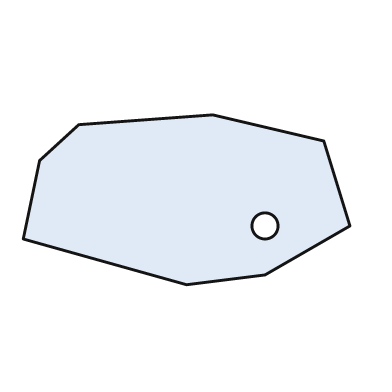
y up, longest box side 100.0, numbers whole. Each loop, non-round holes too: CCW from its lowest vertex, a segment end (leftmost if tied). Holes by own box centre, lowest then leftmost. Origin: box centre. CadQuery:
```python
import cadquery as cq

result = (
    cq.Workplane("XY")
    .moveTo(0.0, -26.0)
    .lineTo(24.0, -23.0)
    .lineTo(50.0, -8.0)
    .lineTo(42.0, 18.0)
    .lineTo(8.0, 26.0)
    .lineTo(-33.0, 23.0)
    .lineTo(-45.0, 12.0)
    .lineTo(-50.0, -12.0)
    .close()
    .moveTo(24.0, -8.0)
    .circle(4.0)
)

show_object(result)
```